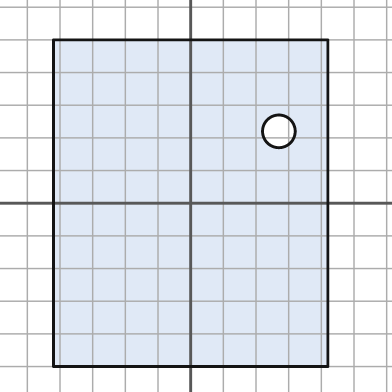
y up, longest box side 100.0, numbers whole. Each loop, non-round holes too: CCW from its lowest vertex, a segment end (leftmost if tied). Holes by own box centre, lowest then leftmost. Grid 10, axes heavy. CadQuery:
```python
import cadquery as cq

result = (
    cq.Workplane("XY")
    .moveTo(-42.0, -50.0)
    .lineTo(42.0, -50.0)
    .lineTo(42.0, 50.0)
    .lineTo(-42.0, 50.0)
    .close()
    .moveTo(27.0, 22.0)
    .circle(5.0)
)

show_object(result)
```